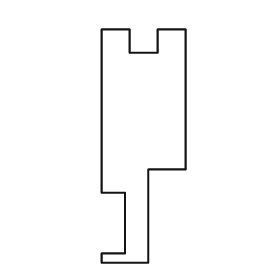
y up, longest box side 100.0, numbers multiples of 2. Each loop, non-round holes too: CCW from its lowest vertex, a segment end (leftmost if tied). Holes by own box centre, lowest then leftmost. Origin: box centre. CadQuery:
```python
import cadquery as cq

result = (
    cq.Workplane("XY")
    .moveTo(-18.0, -50.0)
    .lineTo(2.0, -50.0)
    .lineTo(2.0, -10.0)
    .lineTo(18.0, -10.0)
    .lineTo(18.0, 50.0)
    .lineTo(6.0, 50.0)
    .lineTo(6.0, 40.0)
    .lineTo(-6.0, 40.0)
    .lineTo(-6.0, 50.0)
    .lineTo(-18.0, 50.0)
    .lineTo(-18.0, -20.0)
    .lineTo(-8.0, -20.0)
    .lineTo(-8.0, -46.0)
    .lineTo(-18.0, -46.0)
    .close()
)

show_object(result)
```